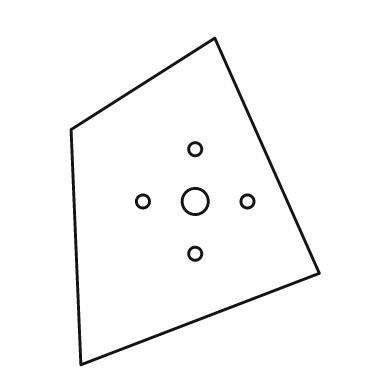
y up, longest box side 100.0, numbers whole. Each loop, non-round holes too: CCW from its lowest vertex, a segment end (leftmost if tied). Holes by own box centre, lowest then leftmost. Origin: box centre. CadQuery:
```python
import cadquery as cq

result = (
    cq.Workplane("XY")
    .moveTo(-35.0, -50.0)
    .lineTo(38.0, -22.0)
    .lineTo(6.0, 50.0)
    .lineTo(-38.0, 22.0)
    .close()
    .moveTo(0.0, -16.0)
    .circle(2.0)
    .moveTo(-16.0, 0.0)
    .circle(2.0)
    .moveTo(0.0, 0.0)
    .circle(4.0)
    .moveTo(16.0, 0.0)
    .circle(2.0)
    .moveTo(0.0, 16.0)
    .circle(2.0)
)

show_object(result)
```